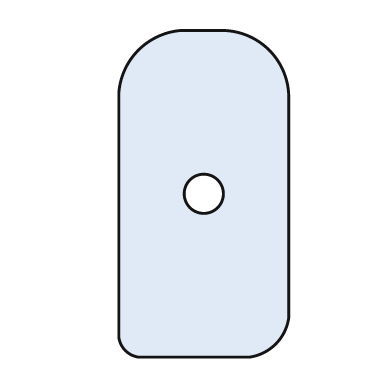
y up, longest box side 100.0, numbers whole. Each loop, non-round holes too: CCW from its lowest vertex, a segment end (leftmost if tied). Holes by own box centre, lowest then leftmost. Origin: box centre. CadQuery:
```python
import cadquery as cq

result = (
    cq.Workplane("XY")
    .moveTo(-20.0, -50.0)
    .lineTo(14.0, -50.0)
    .threePointArc((22.0, -46.0), (26.0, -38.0))
    .lineTo(26.0, 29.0)
    .threePointArc((20.0, 44.0), (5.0, 50.0))
    .lineTo(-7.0, 50.0)
    .threePointArc((-20.0, 44.0), (-26.0, 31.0))
    .lineTo(-26.0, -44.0)
    .threePointArc((-24.0, -48.0), (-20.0, -50.0))
    .close()
    .moveTo(0.0, 0.0)
    .circle(6.0)
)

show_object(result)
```